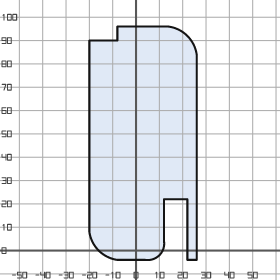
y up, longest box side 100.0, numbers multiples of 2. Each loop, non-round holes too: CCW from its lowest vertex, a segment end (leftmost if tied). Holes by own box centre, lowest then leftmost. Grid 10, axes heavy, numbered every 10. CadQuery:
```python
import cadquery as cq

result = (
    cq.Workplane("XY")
    .moveTo(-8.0, -4.0)
    .lineTo(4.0, -4.0)
    .threePointArc((10.0, -2.0), (12.0, 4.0))
    .lineTo(12.0, 22.0)
    .lineTo(22.0, 22.0)
    .lineTo(22.0, -4.0)
    .lineTo(26.0, -4.0)
    .lineTo(26.0, 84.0)
    .threePointArc((22.0, 92.0), (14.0, 96.0))
    .lineTo(-8.0, 96.0)
    .lineTo(-8.0, 90.0)
    .lineTo(-20.0, 90.0)
    .lineTo(-20.0, 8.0)
    .threePointArc((-16.0, 0.0), (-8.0, -4.0))
    .close()
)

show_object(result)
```